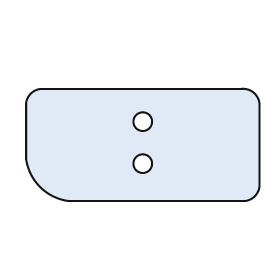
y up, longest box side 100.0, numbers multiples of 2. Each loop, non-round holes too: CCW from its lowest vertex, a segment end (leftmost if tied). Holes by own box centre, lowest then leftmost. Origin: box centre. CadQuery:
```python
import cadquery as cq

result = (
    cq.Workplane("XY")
    .moveTo(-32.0, -24.0)
    .lineTo(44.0, -24.0)
    .threePointArc((48.0, -22.0), (50.0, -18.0))
    .lineTo(50.0, 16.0)
    .threePointArc((48.0, 22.0), (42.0, 24.0))
    .lineTo(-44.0, 24.0)
    .threePointArc((-48.0, 22.0), (-50.0, 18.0))
    .lineTo(-50.0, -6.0)
    .threePointArc((-44.0, -18.0), (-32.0, -24.0))
    .close()
    .moveTo(0.0, -8.0)
    .circle(4.0)
    .moveTo(0.0, 10.0)
    .circle(4.0)
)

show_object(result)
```